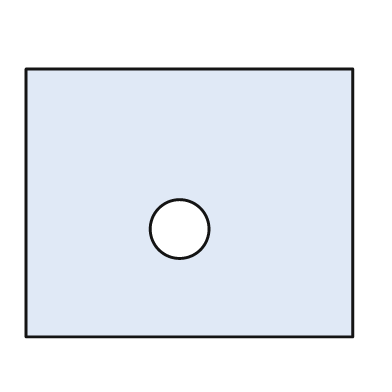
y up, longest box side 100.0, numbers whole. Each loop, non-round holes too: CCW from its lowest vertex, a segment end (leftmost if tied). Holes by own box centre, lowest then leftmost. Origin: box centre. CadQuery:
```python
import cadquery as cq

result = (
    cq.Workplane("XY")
    .moveTo(-50.0, -41.0)
    .lineTo(50.0, -41.0)
    .lineTo(50.0, 41.0)
    .lineTo(-50.0, 41.0)
    .close()
    .moveTo(-3.0, -8.0)
    .circle(9.0)
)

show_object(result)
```